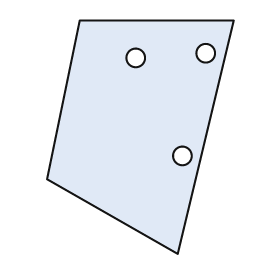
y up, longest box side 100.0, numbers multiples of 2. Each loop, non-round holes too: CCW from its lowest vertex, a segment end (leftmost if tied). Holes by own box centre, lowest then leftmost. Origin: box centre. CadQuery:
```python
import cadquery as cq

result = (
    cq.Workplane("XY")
    .moveTo(16.0, -50.0)
    .lineTo(40.0, 50.0)
    .lineTo(-26.0, 50.0)
    .lineTo(-40.0, -18.0)
    .close()
    .moveTo(18.0, -8.0)
    .circle(4.0)
    .moveTo(-2.0, 34.0)
    .circle(4.0)
    .moveTo(28.0, 36.0)
    .circle(4.0)
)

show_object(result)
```